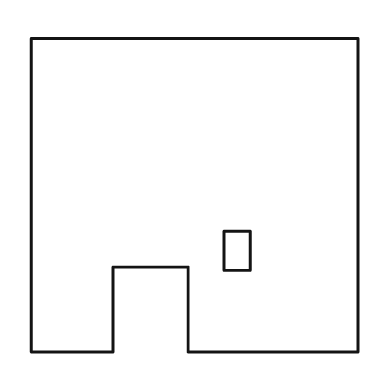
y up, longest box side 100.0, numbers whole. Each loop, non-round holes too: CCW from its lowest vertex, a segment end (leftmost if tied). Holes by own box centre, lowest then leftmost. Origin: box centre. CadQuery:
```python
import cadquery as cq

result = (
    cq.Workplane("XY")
    .moveTo(-50.0, -48.0)
    .lineTo(-25.0, -48.0)
    .lineTo(-25.0, -22.0)
    .lineTo(-2.0, -22.0)
    .lineTo(-2.0, -48.0)
    .lineTo(50.0, -48.0)
    .lineTo(50.0, 48.0)
    .lineTo(-50.0, 48.0)
    .close()
    .moveTo(9.0, -23.0)
    .lineTo(17.0, -23.0)
    .lineTo(17.0, -11.0)
    .lineTo(9.0, -11.0)
    .close()
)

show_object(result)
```